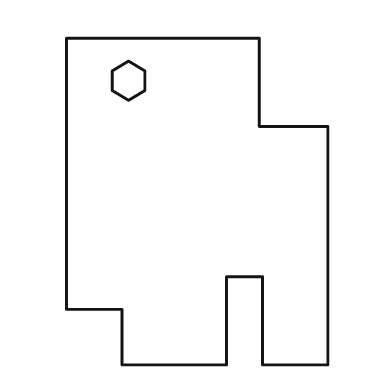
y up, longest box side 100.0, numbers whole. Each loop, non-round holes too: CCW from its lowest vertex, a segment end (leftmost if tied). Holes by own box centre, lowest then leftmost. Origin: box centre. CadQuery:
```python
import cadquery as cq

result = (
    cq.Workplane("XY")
    .moveTo(-23.0, -50.0)
    .lineTo(9.0, -50.0)
    .lineTo(9.0, -23.0)
    .lineTo(20.0, -23.0)
    .lineTo(20.0, -50.0)
    .lineTo(40.0, -50.0)
    .lineTo(40.0, 23.0)
    .lineTo(19.0, 23.0)
    .lineTo(19.0, 50.0)
    .lineTo(-40.0, 50.0)
    .lineTo(-40.0, -33.0)
    .lineTo(-23.0, -33.0)
    .close()
    .moveTo(-21.0, 31.0)
    .lineTo(-16.0, 34.0)
    .lineTo(-16.0, 40.0)
    .lineTo(-21.0, 43.0)
    .lineTo(-26.0, 40.0)
    .lineTo(-26.0, 34.0)
    .close()
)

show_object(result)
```